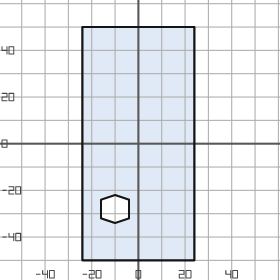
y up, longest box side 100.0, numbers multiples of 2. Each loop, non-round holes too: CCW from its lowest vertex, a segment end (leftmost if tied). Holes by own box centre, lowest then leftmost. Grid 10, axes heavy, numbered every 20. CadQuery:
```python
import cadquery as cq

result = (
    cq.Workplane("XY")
    .moveTo(-24.0, -50.0)
    .lineTo(24.0, -50.0)
    .lineTo(24.0, 50.0)
    .lineTo(-24.0, 50.0)
    .close()
    .moveTo(-10.0, -34.0)
    .lineTo(-4.0, -32.0)
    .lineTo(-4.0, -24.0)
    .lineTo(-10.0, -22.0)
    .lineTo(-16.0, -24.0)
    .lineTo(-16.0, -32.0)
    .close()
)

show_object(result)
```